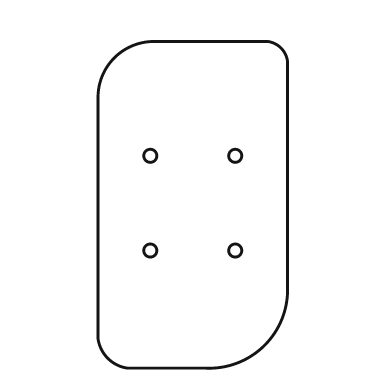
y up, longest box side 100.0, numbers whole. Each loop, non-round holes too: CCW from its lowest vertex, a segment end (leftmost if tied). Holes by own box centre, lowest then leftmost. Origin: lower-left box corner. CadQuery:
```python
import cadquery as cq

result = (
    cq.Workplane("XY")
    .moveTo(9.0, 0.0)
    .lineTo(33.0, 0.0)
    .threePointArc((51.0, 7.0), (58.0, 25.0))
    .lineTo(58.0, 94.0)
    .threePointArc((56.0, 98.0), (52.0, 100.0))
    .lineTo(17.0, 100.0)
    .threePointArc((5.0, 95.0), (0.0, 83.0))
    .lineTo(0.0, 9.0)
    .threePointArc((3.0, 3.0), (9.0, 0.0))
    .close()
    .moveTo(16.0, 36.0)
    .circle(2.0)
    .moveTo(42.0, 36.0)
    .circle(2.0)
    .moveTo(16.0, 65.0)
    .circle(2.0)
    .moveTo(42.0, 65.0)
    .circle(2.0)
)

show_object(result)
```